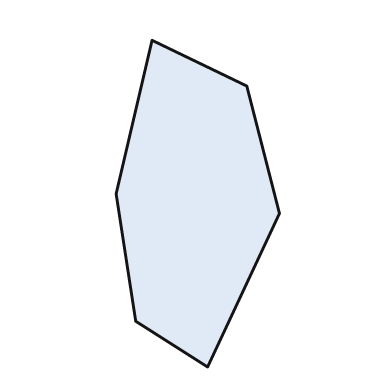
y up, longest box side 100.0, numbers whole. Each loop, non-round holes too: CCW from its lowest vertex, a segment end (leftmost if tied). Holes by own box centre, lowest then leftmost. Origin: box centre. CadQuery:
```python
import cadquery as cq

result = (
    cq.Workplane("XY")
    .moveTo(3.0, -50.0)
    .lineTo(25.0, -3.0)
    .lineTo(15.0, 36.0)
    .lineTo(-14.0, 50.0)
    .lineTo(-25.0, 3.0)
    .lineTo(-19.0, -36.0)
    .close()
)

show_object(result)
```